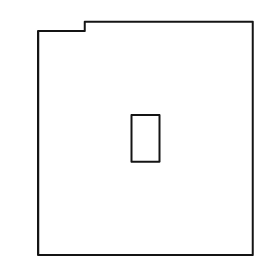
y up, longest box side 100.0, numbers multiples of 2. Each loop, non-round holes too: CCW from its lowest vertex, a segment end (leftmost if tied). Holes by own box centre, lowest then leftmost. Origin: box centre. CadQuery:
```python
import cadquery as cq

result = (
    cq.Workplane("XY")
    .moveTo(-46.0, -50.0)
    .lineTo(46.0, -50.0)
    .lineTo(46.0, 50.0)
    .lineTo(-26.0, 50.0)
    .lineTo(-26.0, 46.0)
    .lineTo(-46.0, 46.0)
    .close()
    .moveTo(-6.0, -10.0)
    .lineTo(6.0, -10.0)
    .lineTo(6.0, 10.0)
    .lineTo(-6.0, 10.0)
    .close()
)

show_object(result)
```